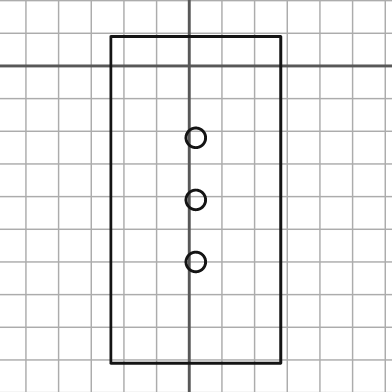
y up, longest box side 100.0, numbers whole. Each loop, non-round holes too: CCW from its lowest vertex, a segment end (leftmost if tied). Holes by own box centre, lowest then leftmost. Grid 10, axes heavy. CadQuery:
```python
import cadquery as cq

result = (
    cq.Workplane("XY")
    .moveTo(-24.0, -91.0)
    .lineTo(28.0, -91.0)
    .lineTo(28.0, 9.0)
    .lineTo(-24.0, 9.0)
    .close()
    .moveTo(2.0, -60.0)
    .circle(3.0)
    .moveTo(2.0, -41.0)
    .circle(3.0)
    .moveTo(2.0, -22.0)
    .circle(3.0)
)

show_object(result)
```